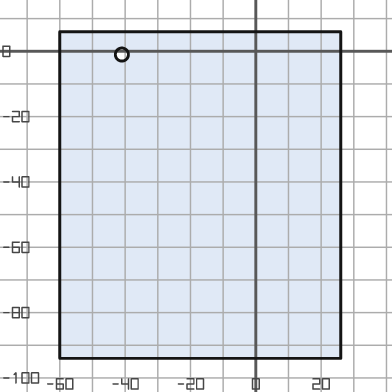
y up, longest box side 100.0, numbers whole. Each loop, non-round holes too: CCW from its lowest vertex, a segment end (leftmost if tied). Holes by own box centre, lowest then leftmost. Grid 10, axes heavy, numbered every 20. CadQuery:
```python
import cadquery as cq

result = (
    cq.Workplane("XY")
    .moveTo(-60.0, -94.0)
    .lineTo(26.0, -94.0)
    .lineTo(26.0, 6.0)
    .lineTo(-60.0, 6.0)
    .close()
    .moveTo(-41.0, -1.0)
    .circle(2.0)
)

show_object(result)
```